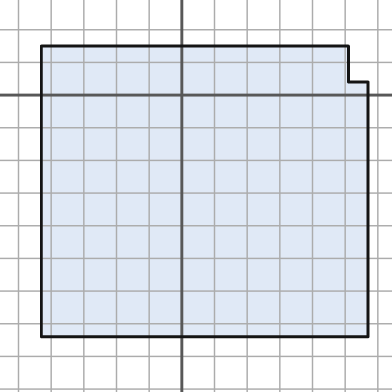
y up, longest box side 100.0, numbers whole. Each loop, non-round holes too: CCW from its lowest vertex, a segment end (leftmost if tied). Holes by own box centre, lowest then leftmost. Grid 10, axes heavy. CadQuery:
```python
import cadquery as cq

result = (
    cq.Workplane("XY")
    .moveTo(-43.0, -74.0)
    .lineTo(57.0, -74.0)
    .lineTo(57.0, 4.0)
    .lineTo(51.0, 4.0)
    .lineTo(51.0, 15.0)
    .lineTo(-43.0, 15.0)
    .close()
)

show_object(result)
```